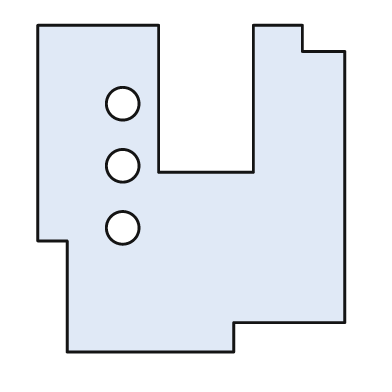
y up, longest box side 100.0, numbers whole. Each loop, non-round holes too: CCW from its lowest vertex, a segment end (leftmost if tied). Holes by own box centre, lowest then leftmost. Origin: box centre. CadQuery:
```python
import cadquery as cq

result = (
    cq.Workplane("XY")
    .moveTo(-38.0, -50.0)
    .lineTo(13.0, -50.0)
    .lineTo(13.0, -41.0)
    .lineTo(47.0, -41.0)
    .lineTo(47.0, 42.0)
    .lineTo(34.0, 42.0)
    .lineTo(34.0, 50.0)
    .lineTo(19.0, 50.0)
    .lineTo(19.0, 5.0)
    .lineTo(-10.0, 5.0)
    .lineTo(-10.0, 50.0)
    .lineTo(-47.0, 50.0)
    .lineTo(-47.0, -16.0)
    .lineTo(-38.0, -16.0)
    .close()
    .moveTo(-21.0, -12.0)
    .circle(5.0)
    .moveTo(-21.0, 7.0)
    .circle(5.0)
    .moveTo(-21.0, 26.0)
    .circle(5.0)
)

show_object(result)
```